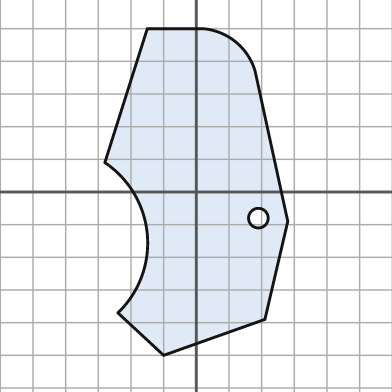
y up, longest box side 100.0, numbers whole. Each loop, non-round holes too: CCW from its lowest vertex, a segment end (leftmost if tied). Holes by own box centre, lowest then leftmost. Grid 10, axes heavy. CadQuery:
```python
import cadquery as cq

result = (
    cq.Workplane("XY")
    .moveTo(-10.0, -50.0)
    .lineTo(21.0, -39.0)
    .lineTo(28.0, -9.0)
    .lineTo(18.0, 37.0)
    .threePointArc((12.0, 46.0), (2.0, 50.0))
    .lineTo(-15.0, 50.0)
    .lineTo(-28.0, 9.0)
    .threePointArc((-15.0, -13.0), (-24.0, -37.0))
    .close()
    .moveTo(19.0, -8.0)
    .circle(3.0)
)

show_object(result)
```